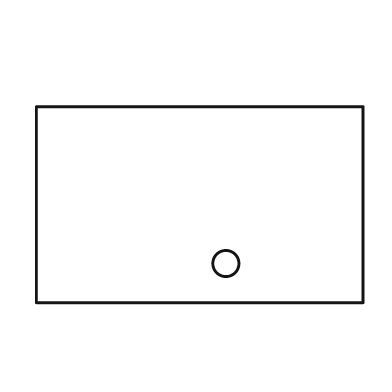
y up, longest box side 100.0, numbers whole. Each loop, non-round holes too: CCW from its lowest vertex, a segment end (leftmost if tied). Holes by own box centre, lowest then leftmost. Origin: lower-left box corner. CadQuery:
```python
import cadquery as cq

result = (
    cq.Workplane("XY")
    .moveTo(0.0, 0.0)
    .lineTo(100.0, 0.0)
    .lineTo(100.0, 60.0)
    .lineTo(0.0, 60.0)
    .close()
    .moveTo(58.0, 12.0)
    .circle(4.0)
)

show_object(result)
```